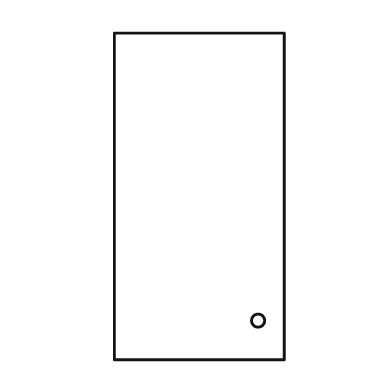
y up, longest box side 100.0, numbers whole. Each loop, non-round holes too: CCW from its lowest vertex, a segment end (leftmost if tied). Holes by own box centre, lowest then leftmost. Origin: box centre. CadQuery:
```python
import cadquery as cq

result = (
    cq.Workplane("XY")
    .moveTo(-26.0, -50.0)
    .lineTo(26.0, -50.0)
    .lineTo(26.0, 50.0)
    .lineTo(-26.0, 50.0)
    .close()
    .moveTo(18.0, -38.0)
    .circle(2.0)
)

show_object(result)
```